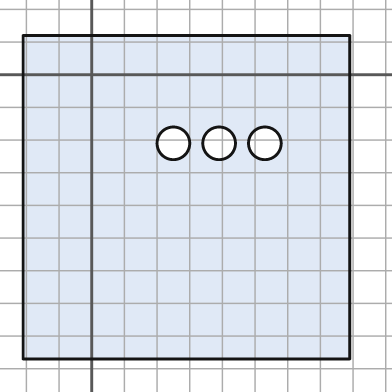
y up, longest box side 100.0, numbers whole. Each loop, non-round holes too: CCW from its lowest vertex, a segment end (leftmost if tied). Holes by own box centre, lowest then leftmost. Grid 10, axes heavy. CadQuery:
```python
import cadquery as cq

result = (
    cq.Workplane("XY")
    .moveTo(-21.0, -87.0)
    .lineTo(79.0, -87.0)
    .lineTo(79.0, 12.0)
    .lineTo(-21.0, 12.0)
    .close()
    .moveTo(25.0, -21.0)
    .circle(5.0)
    .moveTo(39.0, -21.0)
    .circle(5.0)
    .moveTo(53.0, -21.0)
    .circle(5.0)
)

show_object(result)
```